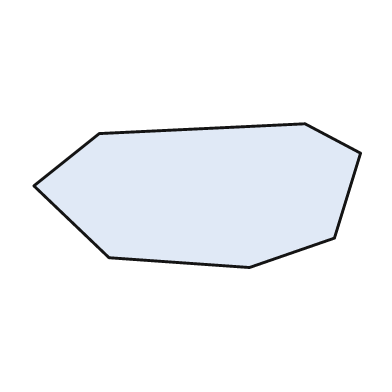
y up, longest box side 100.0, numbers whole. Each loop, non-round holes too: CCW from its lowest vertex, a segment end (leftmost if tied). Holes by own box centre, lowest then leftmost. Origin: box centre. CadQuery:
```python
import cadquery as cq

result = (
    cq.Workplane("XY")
    .moveTo(16.0, -22.0)
    .lineTo(42.0, -13.0)
    .lineTo(50.0, 13.0)
    .lineTo(33.0, 22.0)
    .lineTo(-30.0, 19.0)
    .lineTo(-50.0, 3.0)
    .lineTo(-27.0, -19.0)
    .close()
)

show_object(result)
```